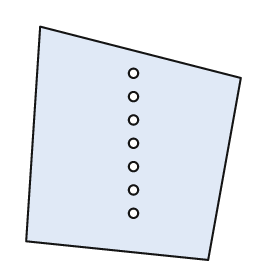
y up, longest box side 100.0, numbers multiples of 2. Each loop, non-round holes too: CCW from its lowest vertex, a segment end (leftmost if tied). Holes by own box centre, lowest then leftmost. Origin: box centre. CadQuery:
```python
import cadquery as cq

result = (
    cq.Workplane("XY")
    .moveTo(32.0, -50.0)
    .lineTo(46.0, 28.0)
    .lineTo(-40.0, 50.0)
    .lineTo(-46.0, -42.0)
    .close()
    .moveTo(0.0, -30.0)
    .circle(2.0)
    .moveTo(0.0, -20.0)
    .circle(2.0)
    .moveTo(0.0, -10.0)
    .circle(2.0)
    .moveTo(0.0, 0.0)
    .circle(2.0)
    .moveTo(0.0, 10.0)
    .circle(2.0)
    .moveTo(0.0, 20.0)
    .circle(2.0)
    .moveTo(0.0, 30.0)
    .circle(2.0)
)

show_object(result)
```